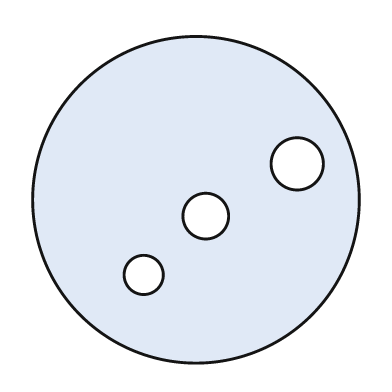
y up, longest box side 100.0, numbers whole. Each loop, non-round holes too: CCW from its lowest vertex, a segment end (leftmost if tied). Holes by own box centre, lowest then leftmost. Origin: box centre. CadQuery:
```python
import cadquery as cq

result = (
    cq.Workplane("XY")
    .moveTo(0.0, 0.0)
    .circle(50.0)
    .moveTo(-16.0, -23.0)
    .circle(6.0)
    .moveTo(3.0, -5.0)
    .circle(7.0)
    .moveTo(31.0, 11.0)
    .circle(8.0)
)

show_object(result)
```